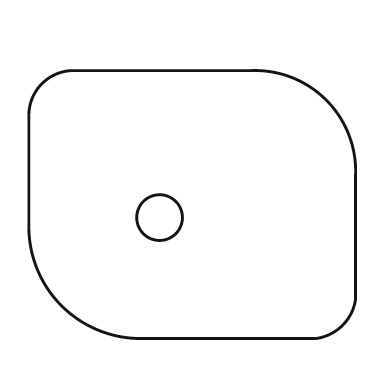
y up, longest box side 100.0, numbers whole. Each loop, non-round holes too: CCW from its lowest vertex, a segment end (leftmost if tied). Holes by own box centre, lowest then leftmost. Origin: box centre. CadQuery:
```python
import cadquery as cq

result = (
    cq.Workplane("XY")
    .moveTo(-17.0, -41.0)
    .lineTo(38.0, -41.0)
    .threePointArc((46.0, -37.0), (50.0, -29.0))
    .lineTo(50.0, 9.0)
    .threePointArc((41.0, 32.0), (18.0, 41.0))
    .lineTo(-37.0, 41.0)
    .threePointArc((-46.0, 37.0), (-50.0, 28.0))
    .lineTo(-50.0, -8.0)
    .threePointArc((-40.0, -31.0), (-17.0, -41.0))
    .close()
    .moveTo(-10.0, -4.0)
    .circle(7.0)
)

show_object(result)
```